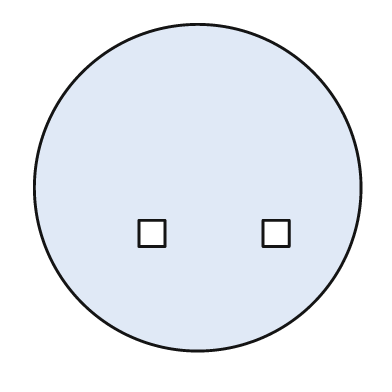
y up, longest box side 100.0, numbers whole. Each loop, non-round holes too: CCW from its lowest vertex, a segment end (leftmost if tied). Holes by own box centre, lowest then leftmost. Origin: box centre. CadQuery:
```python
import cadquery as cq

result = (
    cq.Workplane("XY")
    .moveTo(0.0, 0.0)
    .circle(50.0)
    .moveTo(-18.0, -18.0)
    .lineTo(-10.0, -18.0)
    .lineTo(-10.0, -10.0)
    .lineTo(-18.0, -10.0)
    .close()
    .moveTo(20.0, -18.0)
    .lineTo(28.0, -18.0)
    .lineTo(28.0, -10.0)
    .lineTo(20.0, -10.0)
    .close()
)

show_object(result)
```